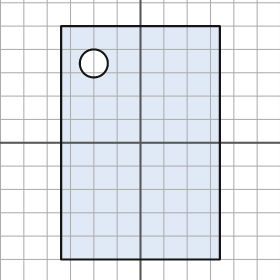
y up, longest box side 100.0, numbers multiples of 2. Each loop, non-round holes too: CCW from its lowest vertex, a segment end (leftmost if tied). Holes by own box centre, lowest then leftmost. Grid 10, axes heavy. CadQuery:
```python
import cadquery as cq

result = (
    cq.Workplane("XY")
    .moveTo(-34.0, -50.0)
    .lineTo(34.0, -50.0)
    .lineTo(34.0, 50.0)
    .lineTo(-34.0, 50.0)
    .close()
    .moveTo(-20.0, 34.0)
    .circle(6.0)
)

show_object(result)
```